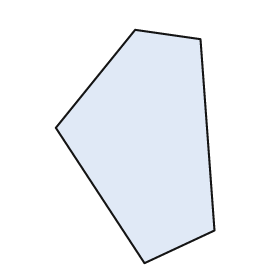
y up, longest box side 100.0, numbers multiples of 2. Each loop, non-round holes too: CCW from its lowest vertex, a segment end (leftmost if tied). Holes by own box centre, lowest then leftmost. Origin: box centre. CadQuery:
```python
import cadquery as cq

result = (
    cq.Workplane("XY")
    .moveTo(4.0, -50.0)
    .lineTo(34.0, -36.0)
    .lineTo(28.0, 46.0)
    .lineTo(0.0, 50.0)
    .lineTo(-34.0, 8.0)
    .close()
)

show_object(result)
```